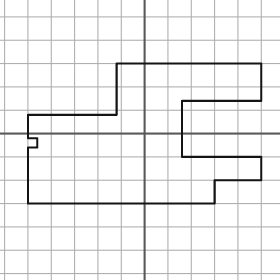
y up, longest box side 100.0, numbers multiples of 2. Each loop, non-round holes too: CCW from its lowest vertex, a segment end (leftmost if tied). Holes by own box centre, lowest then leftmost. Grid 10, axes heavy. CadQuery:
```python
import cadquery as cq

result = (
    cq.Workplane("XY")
    .moveTo(-50.0, -30.0)
    .lineTo(30.0, -30.0)
    .lineTo(30.0, -20.0)
    .lineTo(50.0, -20.0)
    .lineTo(50.0, -10.0)
    .lineTo(16.0, -10.0)
    .lineTo(16.0, 14.0)
    .lineTo(50.0, 14.0)
    .lineTo(50.0, 30.0)
    .lineTo(-12.0, 30.0)
    .lineTo(-12.0, 8.0)
    .lineTo(-50.0, 8.0)
    .lineTo(-50.0, -2.0)
    .lineTo(-46.0, -2.0)
    .lineTo(-46.0, -6.0)
    .lineTo(-50.0, -6.0)
    .close()
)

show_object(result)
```